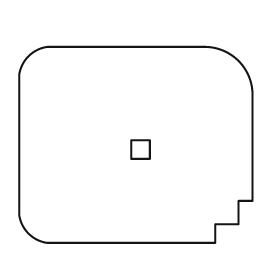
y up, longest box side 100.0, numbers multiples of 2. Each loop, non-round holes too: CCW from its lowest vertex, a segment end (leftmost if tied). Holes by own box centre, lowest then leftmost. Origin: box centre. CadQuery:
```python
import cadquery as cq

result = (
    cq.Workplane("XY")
    .moveTo(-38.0, -42.0)
    .lineTo(34.0, -42.0)
    .lineTo(34.0, -34.0)
    .lineTo(44.0, -34.0)
    .lineTo(44.0, -24.0)
    .lineTo(50.0, -24.0)
    .lineTo(50.0, 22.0)
    .threePointArc((44.0, 36.0), (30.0, 42.0))
    .lineTo(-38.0, 42.0)
    .threePointArc((-46.0, 38.0), (-50.0, 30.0))
    .lineTo(-50.0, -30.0)
    .threePointArc((-46.0, -38.0), (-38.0, -42.0))
    .close()
    .moveTo(-2.0, -6.0)
    .lineTo(6.0, -6.0)
    .lineTo(6.0, 2.0)
    .lineTo(-2.0, 2.0)
    .close()
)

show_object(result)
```